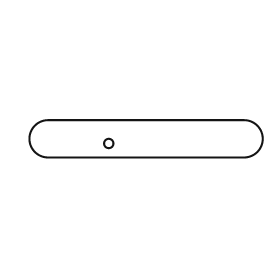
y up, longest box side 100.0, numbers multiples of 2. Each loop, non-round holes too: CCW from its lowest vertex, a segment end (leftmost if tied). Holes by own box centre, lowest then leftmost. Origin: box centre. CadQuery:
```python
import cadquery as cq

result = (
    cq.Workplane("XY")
    .moveTo(-42.0, -8.0)
    .lineTo(42.0, -8.0)
    .threePointArc((50.0, 0.0), (42.0, 8.0))
    .lineTo(-42.0, 8.0)
    .threePointArc((-50.0, 0.0), (-42.0, -8.0))
    .close()
    .moveTo(-16.0, -2.0)
    .circle(2.0)
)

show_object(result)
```